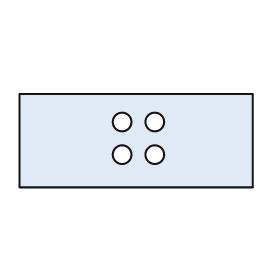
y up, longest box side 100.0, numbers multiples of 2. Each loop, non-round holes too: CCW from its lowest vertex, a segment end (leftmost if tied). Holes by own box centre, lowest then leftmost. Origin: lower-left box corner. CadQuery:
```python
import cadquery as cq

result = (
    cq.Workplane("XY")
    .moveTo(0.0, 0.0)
    .lineTo(100.0, 0.0)
    .lineTo(100.0, 40.0)
    .lineTo(0.0, 40.0)
    .close()
    .moveTo(44.0, 14.0)
    .circle(4.0)
    .moveTo(58.0, 14.0)
    .circle(4.0)
    .moveTo(44.0, 28.0)
    .circle(4.0)
    .moveTo(58.0, 28.0)
    .circle(4.0)
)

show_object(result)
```